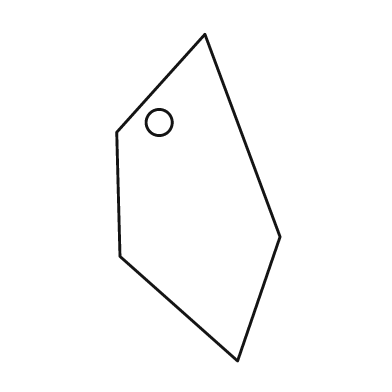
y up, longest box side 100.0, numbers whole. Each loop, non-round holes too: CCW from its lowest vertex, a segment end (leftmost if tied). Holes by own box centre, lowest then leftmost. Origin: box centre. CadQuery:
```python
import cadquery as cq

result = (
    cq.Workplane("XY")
    .moveTo(12.0, -50.0)
    .lineTo(25.0, -12.0)
    .lineTo(2.0, 50.0)
    .lineTo(-25.0, 20.0)
    .lineTo(-24.0, -18.0)
    .close()
    .moveTo(-12.0, 23.0)
    .circle(4.0)
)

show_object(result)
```